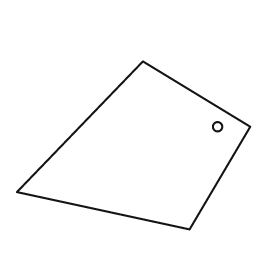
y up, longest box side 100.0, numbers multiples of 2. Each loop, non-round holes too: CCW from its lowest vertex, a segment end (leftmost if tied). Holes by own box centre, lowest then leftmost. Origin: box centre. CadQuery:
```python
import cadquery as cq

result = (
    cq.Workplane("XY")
    .moveTo(24.0, -36.0)
    .lineTo(50.0, 8.0)
    .lineTo(4.0, 36.0)
    .lineTo(-50.0, -20.0)
    .close()
    .moveTo(36.0, 8.0)
    .circle(2.0)
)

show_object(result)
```